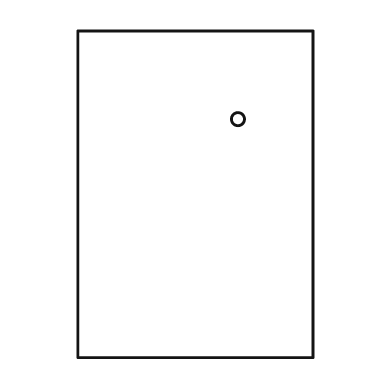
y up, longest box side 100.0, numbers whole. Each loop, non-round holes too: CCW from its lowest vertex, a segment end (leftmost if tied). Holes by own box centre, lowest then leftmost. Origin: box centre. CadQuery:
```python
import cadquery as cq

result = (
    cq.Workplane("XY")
    .moveTo(-36.0, -50.0)
    .lineTo(36.0, -50.0)
    .lineTo(36.0, 50.0)
    .lineTo(-36.0, 50.0)
    .close()
    .moveTo(13.0, 23.0)
    .circle(2.0)
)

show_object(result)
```